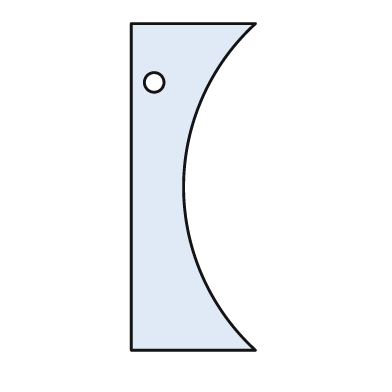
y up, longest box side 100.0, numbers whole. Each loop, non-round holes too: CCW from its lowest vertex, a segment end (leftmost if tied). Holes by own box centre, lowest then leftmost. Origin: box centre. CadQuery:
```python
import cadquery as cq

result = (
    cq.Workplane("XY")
    .moveTo(-19.0, -50.0)
    .lineTo(19.0, -50.0)
    .threePointArc((-3.0, 0.0), (19.0, 50.0))
    .lineTo(-19.0, 50.0)
    .close()
    .moveTo(-12.0, 32.0)
    .circle(3.0)
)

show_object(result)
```